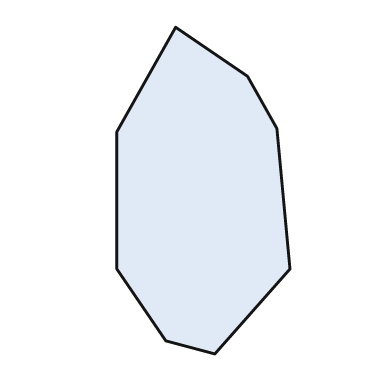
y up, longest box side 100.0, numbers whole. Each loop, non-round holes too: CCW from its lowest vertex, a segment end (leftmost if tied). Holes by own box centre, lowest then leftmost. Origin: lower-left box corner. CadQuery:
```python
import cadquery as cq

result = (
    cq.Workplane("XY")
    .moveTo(30.0, 0.0)
    .lineTo(53.0, 26.0)
    .lineTo(49.0, 69.0)
    .lineTo(40.0, 85.0)
    .lineTo(18.0, 100.0)
    .lineTo(0.0, 68.0)
    .lineTo(0.0, 26.0)
    .lineTo(15.0, 4.0)
    .close()
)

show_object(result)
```